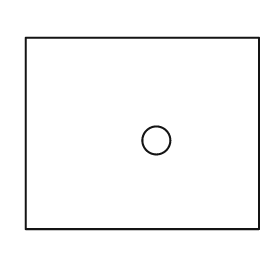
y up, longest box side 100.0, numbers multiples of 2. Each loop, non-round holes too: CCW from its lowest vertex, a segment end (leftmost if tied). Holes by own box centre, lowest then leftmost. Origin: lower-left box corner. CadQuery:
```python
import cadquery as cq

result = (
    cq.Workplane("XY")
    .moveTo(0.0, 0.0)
    .lineTo(100.0, 0.0)
    .lineTo(100.0, 82.0)
    .lineTo(0.0, 82.0)
    .close()
    .moveTo(56.0, 38.0)
    .circle(6.0)
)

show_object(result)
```